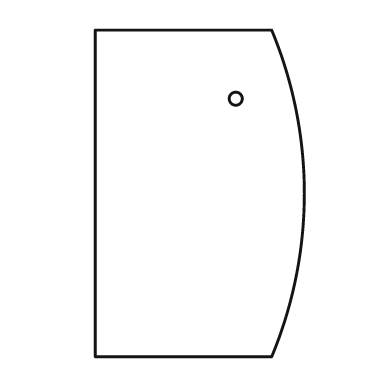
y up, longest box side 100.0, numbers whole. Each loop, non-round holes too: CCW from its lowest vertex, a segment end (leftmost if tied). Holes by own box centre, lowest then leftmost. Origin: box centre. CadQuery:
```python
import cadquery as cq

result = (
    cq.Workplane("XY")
    .moveTo(-32.0, -50.0)
    .lineTo(22.0, -50.0)
    .threePointArc((32.0, 0.0), (22.0, 50.0))
    .lineTo(-32.0, 50.0)
    .close()
    .moveTo(11.0, 29.0)
    .circle(2.0)
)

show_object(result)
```